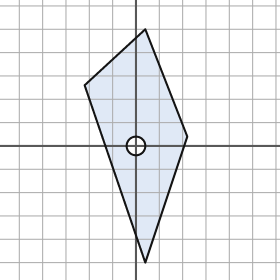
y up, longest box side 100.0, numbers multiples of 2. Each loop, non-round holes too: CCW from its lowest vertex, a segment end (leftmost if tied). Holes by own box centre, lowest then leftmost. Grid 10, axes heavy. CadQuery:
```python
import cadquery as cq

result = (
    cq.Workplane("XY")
    .moveTo(4.0, -50.0)
    .lineTo(22.0, 4.0)
    .lineTo(4.0, 50.0)
    .lineTo(-22.0, 26.0)
    .close()
    .moveTo(0.0, 0.0)
    .circle(4.0)
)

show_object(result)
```